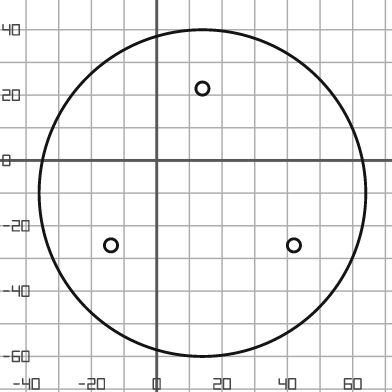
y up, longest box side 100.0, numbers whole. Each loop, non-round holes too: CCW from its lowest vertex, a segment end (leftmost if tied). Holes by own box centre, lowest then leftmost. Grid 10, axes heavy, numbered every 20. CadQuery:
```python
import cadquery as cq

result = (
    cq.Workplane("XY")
    .moveTo(14.0, -10.0)
    .circle(50.0)
    .moveTo(-14.0, -26.0)
    .circle(2.0)
    .moveTo(42.0, -26.0)
    .circle(2.0)
    .moveTo(14.0, 22.0)
    .circle(2.0)
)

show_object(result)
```